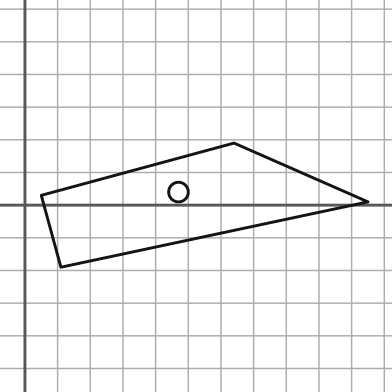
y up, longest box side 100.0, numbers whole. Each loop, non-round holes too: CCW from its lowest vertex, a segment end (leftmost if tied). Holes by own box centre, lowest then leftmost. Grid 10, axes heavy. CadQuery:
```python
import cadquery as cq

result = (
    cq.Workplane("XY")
    .moveTo(11.0, -19.0)
    .lineTo(105.0, 1.0)
    .lineTo(64.0, 19.0)
    .lineTo(5.0, 3.0)
    .close()
    .moveTo(47.0, 4.0)
    .circle(3.0)
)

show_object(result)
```